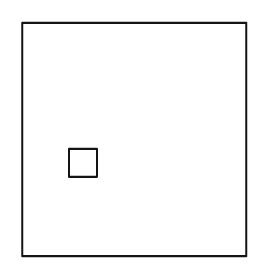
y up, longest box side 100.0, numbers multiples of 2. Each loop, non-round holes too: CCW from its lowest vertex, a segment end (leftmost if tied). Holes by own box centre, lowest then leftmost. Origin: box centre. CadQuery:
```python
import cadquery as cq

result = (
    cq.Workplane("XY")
    .moveTo(-48.0, -50.0)
    .lineTo(48.0, -50.0)
    .lineTo(48.0, 50.0)
    .lineTo(-48.0, 50.0)
    .close()
    .moveTo(-28.0, -16.0)
    .lineTo(-16.0, -16.0)
    .lineTo(-16.0, -4.0)
    .lineTo(-28.0, -4.0)
    .close()
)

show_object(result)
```